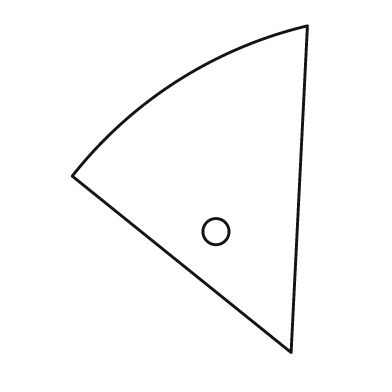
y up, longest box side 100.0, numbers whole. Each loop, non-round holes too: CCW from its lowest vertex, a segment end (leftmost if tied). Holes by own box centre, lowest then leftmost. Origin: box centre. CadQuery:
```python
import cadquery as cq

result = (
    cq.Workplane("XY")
    .moveTo(31.0, -50.0)
    .lineTo(36.0, 50.0)
    .threePointArc((-4.0, 33.0), (-36.0, 4.0))
    .close()
    .moveTo(8.0, -13.0)
    .circle(4.0)
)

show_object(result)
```